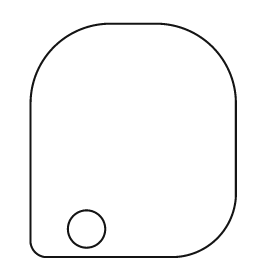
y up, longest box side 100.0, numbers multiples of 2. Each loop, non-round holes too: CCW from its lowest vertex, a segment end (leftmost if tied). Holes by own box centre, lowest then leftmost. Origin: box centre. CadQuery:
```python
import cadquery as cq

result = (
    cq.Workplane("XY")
    .moveTo(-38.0, -50.0)
    .lineTo(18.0, -50.0)
    .threePointArc((36.0, -42.0), (44.0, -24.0))
    .lineTo(44.0, 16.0)
    .threePointArc((34.0, 40.0), (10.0, 50.0))
    .lineTo(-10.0, 50.0)
    .threePointArc((-34.0, 40.0), (-44.0, 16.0))
    .lineTo(-44.0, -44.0)
    .threePointArc((-42.0, -48.0), (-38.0, -50.0))
    .close()
    .moveTo(-20.0, -38.0)
    .circle(8.0)
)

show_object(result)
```